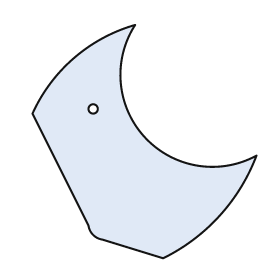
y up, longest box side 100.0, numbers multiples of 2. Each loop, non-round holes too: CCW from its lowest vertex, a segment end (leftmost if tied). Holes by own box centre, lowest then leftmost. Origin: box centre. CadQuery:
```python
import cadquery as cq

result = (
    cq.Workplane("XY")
    .moveTo(8.0, -50.0)
    .threePointArc((32.0, -32.0), (48.0, -6.0))
    .threePointArc((0.0, 2.0), (-4.0, 50.0))
    .threePointArc((-30.0, 36.0), (-48.0, 12.0))
    .lineTo(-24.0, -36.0)
    .threePointArc((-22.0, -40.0), (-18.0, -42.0))
    .close()
    .moveTo(-22.0, 14.0)
    .circle(2.0)
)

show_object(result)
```